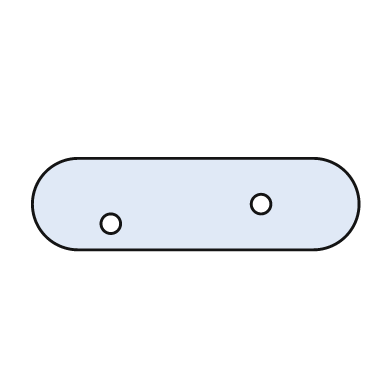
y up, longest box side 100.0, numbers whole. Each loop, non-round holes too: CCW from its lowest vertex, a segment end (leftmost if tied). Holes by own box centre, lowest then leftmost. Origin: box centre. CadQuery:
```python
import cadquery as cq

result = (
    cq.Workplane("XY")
    .moveTo(-36.0, -14.0)
    .lineTo(36.0, -14.0)
    .threePointArc((50.0, 0.0), (36.0, 14.0))
    .lineTo(-36.0, 14.0)
    .threePointArc((-50.0, 0.0), (-36.0, -14.0))
    .close()
    .moveTo(-26.0, -6.0)
    .circle(3.0)
    .moveTo(20.0, 0.0)
    .circle(3.0)
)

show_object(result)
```